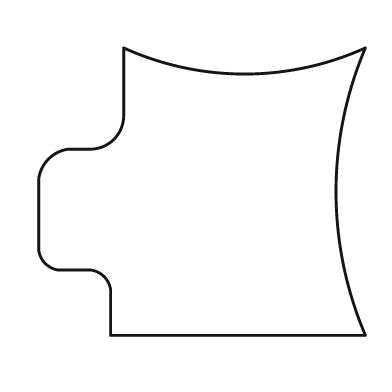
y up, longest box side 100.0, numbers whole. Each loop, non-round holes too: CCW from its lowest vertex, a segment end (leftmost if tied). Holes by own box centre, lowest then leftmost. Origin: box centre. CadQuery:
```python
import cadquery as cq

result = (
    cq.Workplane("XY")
    .moveTo(-28.0, -44.0)
    .lineTo(50.0, -44.0)
    .threePointArc((41.0, 0.0), (50.0, 44.0))
    .threePointArc((13.0, 36.0), (-24.0, 44.0))
    .lineTo(-24.0, 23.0)
    .threePointArc((-27.0, 16.0), (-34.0, 13.0))
    .lineTo(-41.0, 13.0)
    .threePointArc((-47.0, 10.0), (-50.0, 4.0))
    .lineTo(-50.0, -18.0)
    .threePointArc((-48.0, -22.0), (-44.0, -24.0))
    .lineTo(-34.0, -24.0)
    .threePointArc((-30.0, -26.0), (-28.0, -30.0))
    .close()
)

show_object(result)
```